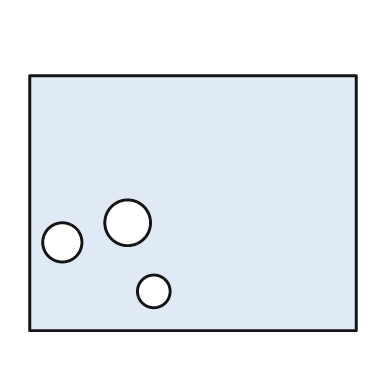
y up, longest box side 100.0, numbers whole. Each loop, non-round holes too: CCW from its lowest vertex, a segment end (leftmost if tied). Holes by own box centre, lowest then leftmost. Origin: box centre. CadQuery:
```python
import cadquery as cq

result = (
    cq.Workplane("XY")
    .moveTo(-50.0, -39.0)
    .lineTo(50.0, -39.0)
    .lineTo(50.0, 39.0)
    .lineTo(-50.0, 39.0)
    .close()
    .moveTo(-12.0, -27.0)
    .circle(5.0)
    .moveTo(-40.0, -12.0)
    .circle(6.0)
    .moveTo(-20.0, -6.0)
    .circle(7.0)
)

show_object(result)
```